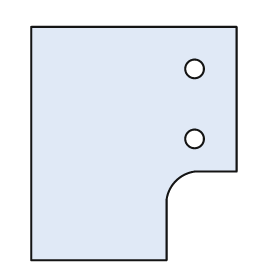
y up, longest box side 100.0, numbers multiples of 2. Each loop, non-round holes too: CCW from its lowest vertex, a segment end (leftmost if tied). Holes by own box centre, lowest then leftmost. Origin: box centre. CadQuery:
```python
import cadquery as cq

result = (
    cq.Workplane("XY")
    .moveTo(-44.0, -50.0)
    .lineTo(14.0, -50.0)
    .lineTo(14.0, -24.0)
    .threePointArc((18.0, -16.0), (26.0, -12.0))
    .lineTo(44.0, -12.0)
    .lineTo(44.0, 50.0)
    .lineTo(-44.0, 50.0)
    .close()
    .moveTo(26.0, 2.0)
    .circle(4.0)
    .moveTo(26.0, 32.0)
    .circle(4.0)
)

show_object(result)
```